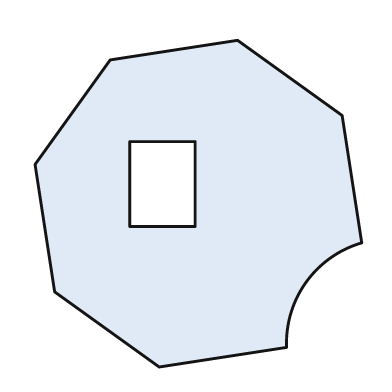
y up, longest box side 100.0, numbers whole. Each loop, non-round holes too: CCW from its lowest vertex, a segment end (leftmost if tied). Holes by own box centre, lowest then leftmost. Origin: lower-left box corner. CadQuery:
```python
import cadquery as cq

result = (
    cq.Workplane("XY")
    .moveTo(38.0, 0.0)
    .lineTo(77.0, 6.0)
    .threePointArc((83.0, 26.0), (100.0, 38.0))
    .lineTo(94.0, 77.0)
    .lineTo(62.0, 100.0)
    .lineTo(23.0, 94.0)
    .lineTo(0.0, 62.0)
    .lineTo(6.0, 23.0)
    .close()
    .moveTo(29.0, 43.0)
    .lineTo(49.0, 43.0)
    .lineTo(49.0, 69.0)
    .lineTo(29.0, 69.0)
    .close()
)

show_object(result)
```